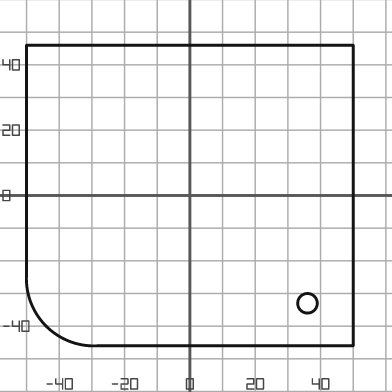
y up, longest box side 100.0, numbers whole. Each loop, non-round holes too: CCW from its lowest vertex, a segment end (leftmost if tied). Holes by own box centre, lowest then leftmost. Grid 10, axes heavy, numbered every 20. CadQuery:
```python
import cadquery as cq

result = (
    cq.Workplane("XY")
    .moveTo(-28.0, -46.0)
    .lineTo(50.0, -46.0)
    .lineTo(50.0, 46.0)
    .lineTo(-50.0, 46.0)
    .lineTo(-50.0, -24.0)
    .threePointArc((-44.0, -40.0), (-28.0, -46.0))
    .close()
    .moveTo(36.0, -33.0)
    .circle(3.0)
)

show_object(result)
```